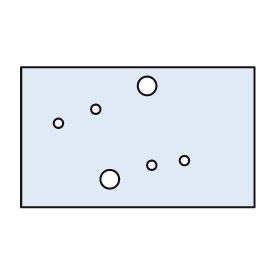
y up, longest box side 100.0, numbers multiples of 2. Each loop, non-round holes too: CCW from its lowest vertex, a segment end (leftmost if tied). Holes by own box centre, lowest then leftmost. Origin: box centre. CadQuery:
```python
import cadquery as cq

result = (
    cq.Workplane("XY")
    .moveTo(-50.0, -30.0)
    .lineTo(50.0, -30.0)
    .lineTo(50.0, 30.0)
    .lineTo(-50.0, 30.0)
    .close()
    .moveTo(-12.0, -18.0)
    .circle(4.0)
    .moveTo(6.0, -12.0)
    .circle(2.0)
    .moveTo(20.0, -10.0)
    .circle(2.0)
    .moveTo(-34.0, 6.0)
    .circle(2.0)
    .moveTo(-18.0, 12.0)
    .circle(2.0)
    .moveTo(4.0, 22.0)
    .circle(4.0)
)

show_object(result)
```